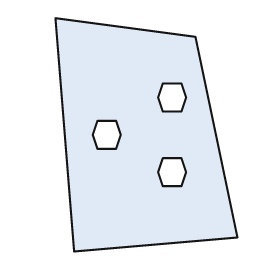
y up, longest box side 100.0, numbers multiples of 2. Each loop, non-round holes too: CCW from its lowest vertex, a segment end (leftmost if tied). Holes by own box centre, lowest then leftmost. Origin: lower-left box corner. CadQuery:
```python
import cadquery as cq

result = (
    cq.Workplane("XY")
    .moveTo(8.0, 0.0)
    .lineTo(78.0, 6.0)
    .lineTo(60.0, 92.0)
    .lineTo(0.0, 100.0)
    .close()
    .moveTo(46.0, 28.0)
    .lineTo(54.0, 28.0)
    .lineTo(56.0, 34.0)
    .lineTo(54.0, 40.0)
    .lineTo(46.0, 40.0)
    .lineTo(44.0, 34.0)
    .close()
    .moveTo(18.0, 44.0)
    .lineTo(26.0, 44.0)
    .lineTo(28.0, 50.0)
    .lineTo(26.0, 56.0)
    .lineTo(18.0, 56.0)
    .lineTo(16.0, 50.0)
    .close()
    .moveTo(46.0, 60.0)
    .lineTo(54.0, 60.0)
    .lineTo(56.0, 66.0)
    .lineTo(54.0, 72.0)
    .lineTo(46.0, 72.0)
    .lineTo(44.0, 66.0)
    .close()
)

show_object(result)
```